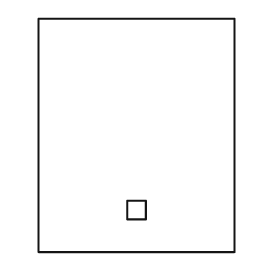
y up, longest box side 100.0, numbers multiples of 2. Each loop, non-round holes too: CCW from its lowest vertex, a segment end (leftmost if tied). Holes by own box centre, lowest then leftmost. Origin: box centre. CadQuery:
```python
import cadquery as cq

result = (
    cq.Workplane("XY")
    .moveTo(-42.0, -50.0)
    .lineTo(42.0, -50.0)
    .lineTo(42.0, 50.0)
    .lineTo(-42.0, 50.0)
    .close()
    .moveTo(-4.0, -36.0)
    .lineTo(4.0, -36.0)
    .lineTo(4.0, -28.0)
    .lineTo(-4.0, -28.0)
    .close()
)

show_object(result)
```